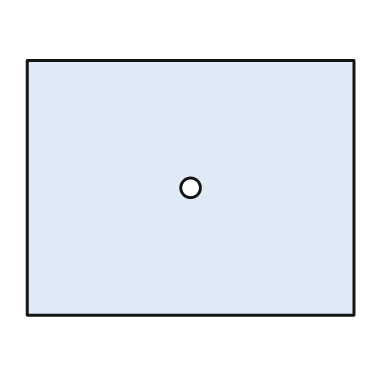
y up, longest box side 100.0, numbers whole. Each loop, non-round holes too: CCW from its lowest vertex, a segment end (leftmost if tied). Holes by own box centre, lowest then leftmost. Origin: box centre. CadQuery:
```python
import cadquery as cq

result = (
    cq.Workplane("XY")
    .moveTo(-50.0, -39.0)
    .lineTo(50.0, -39.0)
    .lineTo(50.0, 39.0)
    .lineTo(-50.0, 39.0)
    .close()
    .moveTo(0.0, 0.0)
    .circle(3.0)
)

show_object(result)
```